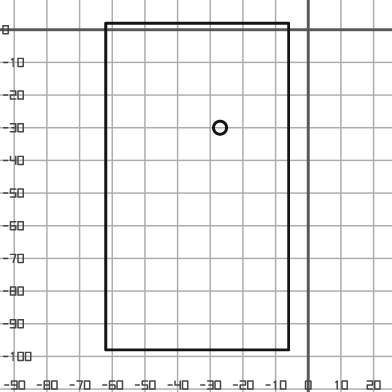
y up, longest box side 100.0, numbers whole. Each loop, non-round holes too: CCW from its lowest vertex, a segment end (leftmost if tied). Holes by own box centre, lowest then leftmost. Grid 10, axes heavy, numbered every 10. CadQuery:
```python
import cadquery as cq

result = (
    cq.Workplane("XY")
    .moveTo(-62.0, -98.0)
    .lineTo(-6.0, -98.0)
    .lineTo(-6.0, 2.0)
    .lineTo(-62.0, 2.0)
    .close()
    .moveTo(-27.0, -30.0)
    .circle(2.0)
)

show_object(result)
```